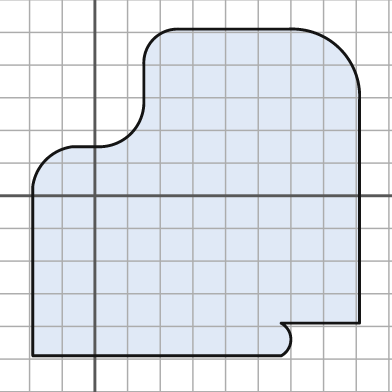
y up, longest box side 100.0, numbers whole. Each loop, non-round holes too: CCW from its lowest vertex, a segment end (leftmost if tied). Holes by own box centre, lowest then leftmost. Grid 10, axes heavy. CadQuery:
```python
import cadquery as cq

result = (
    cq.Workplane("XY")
    .moveTo(-19.0, -49.0)
    .lineTo(57.0, -49.0)
    .threePointArc((60.0, -44.0), (57.0, -39.0))
    .lineTo(81.0, -39.0)
    .lineTo(81.0, 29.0)
    .threePointArc((75.0, 45.0), (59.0, 51.0))
    .lineTo(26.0, 51.0)
    .threePointArc((18.0, 48.0), (15.0, 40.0))
    .lineTo(15.0, 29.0)
    .threePointArc((11.0, 19.0), (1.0, 15.0))
    .lineTo(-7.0, 15.0)
    .threePointArc((-15.0, 11.0), (-19.0, 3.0))
    .close()
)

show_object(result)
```